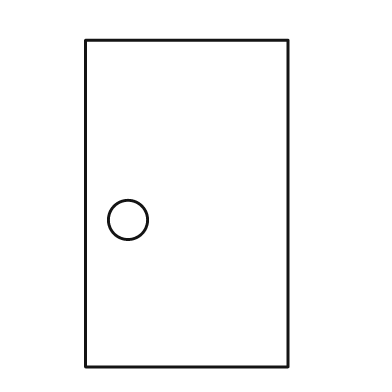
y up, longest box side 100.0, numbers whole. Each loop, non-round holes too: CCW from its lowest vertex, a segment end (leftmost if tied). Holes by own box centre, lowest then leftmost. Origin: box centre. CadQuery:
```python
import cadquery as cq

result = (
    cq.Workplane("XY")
    .moveTo(-31.0, -50.0)
    .lineTo(31.0, -50.0)
    .lineTo(31.0, 50.0)
    .lineTo(-31.0, 50.0)
    .close()
    .moveTo(-18.0, -5.0)
    .circle(6.0)
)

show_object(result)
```